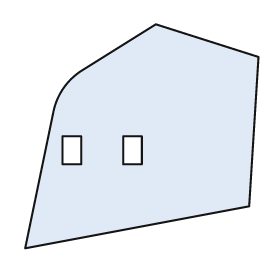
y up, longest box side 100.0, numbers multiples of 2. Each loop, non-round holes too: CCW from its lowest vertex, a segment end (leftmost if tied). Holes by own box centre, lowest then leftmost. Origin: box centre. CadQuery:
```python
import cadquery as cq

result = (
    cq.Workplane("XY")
    .moveTo(-50.0, -48.0)
    .lineTo(46.0, -30.0)
    .lineTo(50.0, 34.0)
    .lineTo(6.0, 48.0)
    .lineTo(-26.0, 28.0)
    .threePointArc((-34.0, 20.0), (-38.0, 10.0))
    .close()
    .moveTo(-34.0, -12.0)
    .lineTo(-26.0, -12.0)
    .lineTo(-26.0, 0.0)
    .lineTo(-34.0, 0.0)
    .close()
    .moveTo(-8.0, -12.0)
    .lineTo(0.0, -12.0)
    .lineTo(0.0, 0.0)
    .lineTo(-8.0, 0.0)
    .close()
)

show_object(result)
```